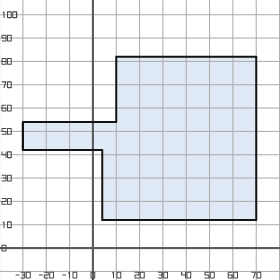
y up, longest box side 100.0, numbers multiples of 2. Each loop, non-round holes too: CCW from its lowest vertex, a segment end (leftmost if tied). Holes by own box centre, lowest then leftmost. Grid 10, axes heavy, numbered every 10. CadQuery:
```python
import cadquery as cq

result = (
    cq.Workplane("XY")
    .moveTo(4.0, 12.0)
    .lineTo(70.0, 12.0)
    .lineTo(70.0, 82.0)
    .lineTo(10.0, 82.0)
    .lineTo(10.0, 54.0)
    .lineTo(-30.0, 54.0)
    .lineTo(-30.0, 42.0)
    .lineTo(4.0, 42.0)
    .close()
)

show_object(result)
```